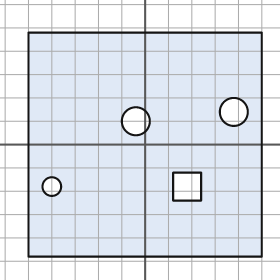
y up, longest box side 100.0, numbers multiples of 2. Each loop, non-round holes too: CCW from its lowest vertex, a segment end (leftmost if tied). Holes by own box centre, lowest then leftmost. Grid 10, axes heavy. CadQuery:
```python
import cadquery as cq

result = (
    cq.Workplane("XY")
    .moveTo(-50.0, -48.0)
    .lineTo(50.0, -48.0)
    .lineTo(50.0, 48.0)
    .lineTo(-50.0, 48.0)
    .close()
    .moveTo(-40.0, -18.0)
    .circle(4.0)
    .moveTo(12.0, -24.0)
    .lineTo(24.0, -24.0)
    .lineTo(24.0, -12.0)
    .lineTo(12.0, -12.0)
    .close()
    .moveTo(-4.0, 10.0)
    .circle(6.0)
    .moveTo(38.0, 14.0)
    .circle(6.0)
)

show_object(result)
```